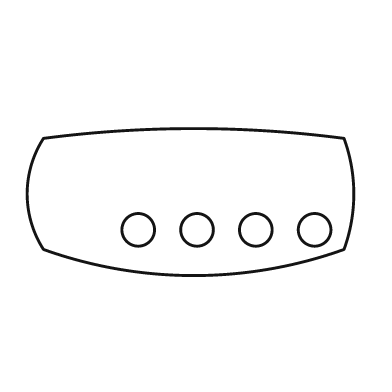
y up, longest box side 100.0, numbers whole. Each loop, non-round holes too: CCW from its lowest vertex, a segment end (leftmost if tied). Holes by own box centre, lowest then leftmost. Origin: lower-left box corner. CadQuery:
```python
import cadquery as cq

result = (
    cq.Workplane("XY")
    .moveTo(5.0, 8.0)
    .threePointArc((51.0, 0.0), (97.0, 8.0))
    .threePointArc((100.0, 25.0), (97.0, 42.0))
    .threePointArc((51.0, 45.0), (5.0, 42.0))
    .threePointArc((0.0, 25.0), (5.0, 8.0))
    .close()
    .moveTo(34.0, 14.0)
    .circle(5.0)
    .moveTo(52.0, 14.0)
    .circle(5.0)
    .moveTo(70.0, 14.0)
    .circle(5.0)
    .moveTo(88.0, 14.0)
    .circle(5.0)
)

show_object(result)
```